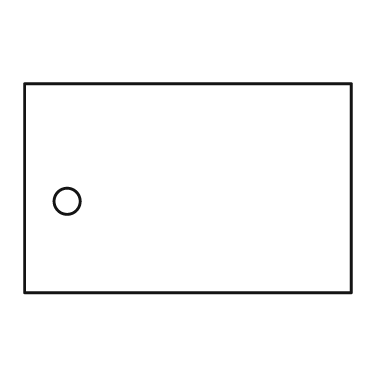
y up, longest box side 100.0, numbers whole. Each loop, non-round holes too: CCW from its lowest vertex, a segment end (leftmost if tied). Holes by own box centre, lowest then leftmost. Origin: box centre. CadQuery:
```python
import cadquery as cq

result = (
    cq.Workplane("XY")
    .moveTo(-50.0, -32.0)
    .lineTo(50.0, -32.0)
    .lineTo(50.0, 32.0)
    .lineTo(-50.0, 32.0)
    .close()
    .moveTo(-37.0, -4.0)
    .circle(4.0)
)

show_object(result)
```